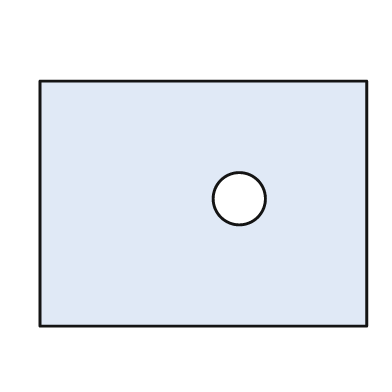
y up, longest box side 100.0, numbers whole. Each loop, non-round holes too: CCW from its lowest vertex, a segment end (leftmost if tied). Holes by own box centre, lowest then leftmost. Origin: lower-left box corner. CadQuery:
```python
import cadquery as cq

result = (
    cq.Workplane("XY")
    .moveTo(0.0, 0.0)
    .lineTo(100.0, 0.0)
    .lineTo(100.0, 75.0)
    .lineTo(0.0, 75.0)
    .close()
    .moveTo(61.0, 39.0)
    .circle(8.0)
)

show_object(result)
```